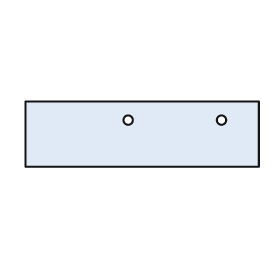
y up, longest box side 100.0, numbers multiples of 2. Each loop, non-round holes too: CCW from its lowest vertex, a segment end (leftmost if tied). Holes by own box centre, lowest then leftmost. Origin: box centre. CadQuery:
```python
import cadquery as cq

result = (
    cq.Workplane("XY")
    .moveTo(-50.0, -14.0)
    .lineTo(50.0, -14.0)
    .lineTo(50.0, 14.0)
    .lineTo(-50.0, 14.0)
    .close()
    .moveTo(-6.0, 6.0)
    .circle(2.0)
    .moveTo(34.0, 6.0)
    .circle(2.0)
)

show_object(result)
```